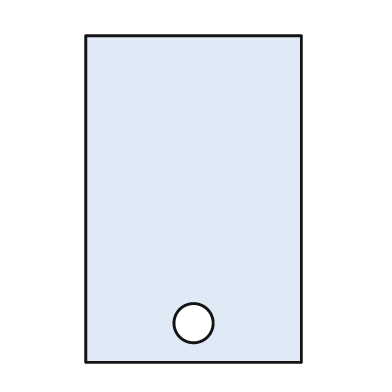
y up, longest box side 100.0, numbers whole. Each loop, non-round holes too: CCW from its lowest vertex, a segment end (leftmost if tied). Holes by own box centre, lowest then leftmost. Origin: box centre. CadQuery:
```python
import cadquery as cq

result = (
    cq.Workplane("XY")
    .moveTo(-33.0, -50.0)
    .lineTo(33.0, -50.0)
    .lineTo(33.0, 50.0)
    .lineTo(-33.0, 50.0)
    .close()
    .moveTo(0.0, -38.0)
    .circle(6.0)
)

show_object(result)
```